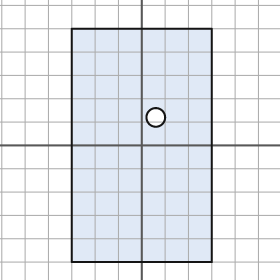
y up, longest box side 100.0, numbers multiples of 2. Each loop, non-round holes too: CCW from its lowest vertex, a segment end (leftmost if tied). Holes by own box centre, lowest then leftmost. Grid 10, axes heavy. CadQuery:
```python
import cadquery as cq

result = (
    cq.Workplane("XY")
    .moveTo(-30.0, -50.0)
    .lineTo(30.0, -50.0)
    .lineTo(30.0, 50.0)
    .lineTo(-30.0, 50.0)
    .close()
    .moveTo(6.0, 12.0)
    .circle(4.0)
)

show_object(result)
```